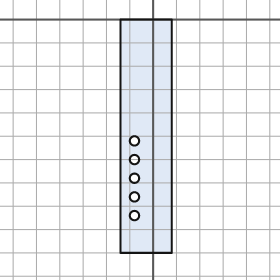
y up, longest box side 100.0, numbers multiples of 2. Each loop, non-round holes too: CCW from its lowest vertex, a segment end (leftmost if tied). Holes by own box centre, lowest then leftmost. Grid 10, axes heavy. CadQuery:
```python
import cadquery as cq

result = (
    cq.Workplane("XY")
    .moveTo(-14.0, -100.0)
    .lineTo(8.0, -100.0)
    .lineTo(8.0, 0.0)
    .lineTo(-14.0, 0.0)
    .close()
    .moveTo(-8.0, -84.0)
    .circle(2.0)
    .moveTo(-8.0, -76.0)
    .circle(2.0)
    .moveTo(-8.0, -68.0)
    .circle(2.0)
    .moveTo(-8.0, -60.0)
    .circle(2.0)
    .moveTo(-8.0, -52.0)
    .circle(2.0)
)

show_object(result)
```